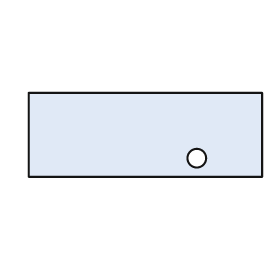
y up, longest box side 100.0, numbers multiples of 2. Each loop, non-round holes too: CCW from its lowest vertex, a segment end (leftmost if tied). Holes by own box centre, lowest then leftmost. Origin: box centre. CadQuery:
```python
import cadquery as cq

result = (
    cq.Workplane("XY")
    .moveTo(-50.0, -18.0)
    .lineTo(50.0, -18.0)
    .lineTo(50.0, 18.0)
    .lineTo(-50.0, 18.0)
    .close()
    .moveTo(22.0, -10.0)
    .circle(4.0)
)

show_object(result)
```